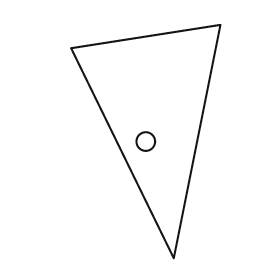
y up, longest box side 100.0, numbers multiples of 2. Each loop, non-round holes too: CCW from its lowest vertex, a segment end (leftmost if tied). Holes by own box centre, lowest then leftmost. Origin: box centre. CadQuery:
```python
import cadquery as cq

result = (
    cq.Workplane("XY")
    .moveTo(12.0, -50.0)
    .lineTo(32.0, 50.0)
    .lineTo(-32.0, 40.0)
    .close()
    .moveTo(0.0, 0.0)
    .circle(4.0)
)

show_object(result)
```